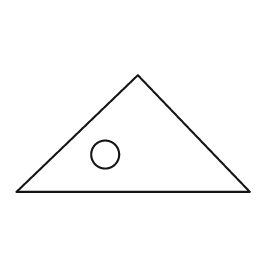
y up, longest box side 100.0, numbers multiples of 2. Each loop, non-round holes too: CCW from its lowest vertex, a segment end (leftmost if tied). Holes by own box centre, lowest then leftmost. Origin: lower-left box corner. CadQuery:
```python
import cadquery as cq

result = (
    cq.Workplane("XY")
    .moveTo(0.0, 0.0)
    .lineTo(100.0, 0.0)
    .lineTo(52.0, 50.0)
    .close()
    .moveTo(38.0, 16.0)
    .circle(6.0)
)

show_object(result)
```